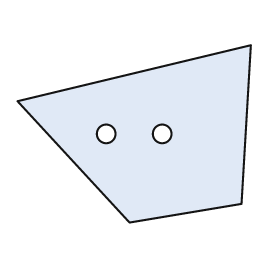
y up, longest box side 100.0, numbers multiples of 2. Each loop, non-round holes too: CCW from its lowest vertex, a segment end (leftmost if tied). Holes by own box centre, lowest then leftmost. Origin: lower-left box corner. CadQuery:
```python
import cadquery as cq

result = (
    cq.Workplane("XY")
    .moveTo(48.0, 0.0)
    .lineTo(96.0, 8.0)
    .lineTo(100.0, 76.0)
    .lineTo(0.0, 52.0)
    .close()
    .moveTo(38.0, 38.0)
    .circle(4.0)
    .moveTo(62.0, 38.0)
    .circle(4.0)
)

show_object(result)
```